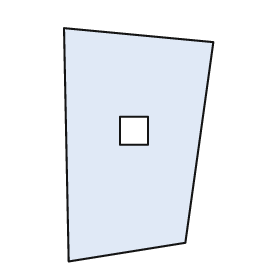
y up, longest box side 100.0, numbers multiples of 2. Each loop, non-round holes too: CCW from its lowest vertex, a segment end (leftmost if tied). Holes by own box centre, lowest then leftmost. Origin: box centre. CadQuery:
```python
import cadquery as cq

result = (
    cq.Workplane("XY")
    .moveTo(-30.0, -50.0)
    .lineTo(20.0, -42.0)
    .lineTo(32.0, 44.0)
    .lineTo(-32.0, 50.0)
    .close()
    .moveTo(-8.0, 0.0)
    .lineTo(4.0, 0.0)
    .lineTo(4.0, 12.0)
    .lineTo(-8.0, 12.0)
    .close()
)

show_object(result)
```